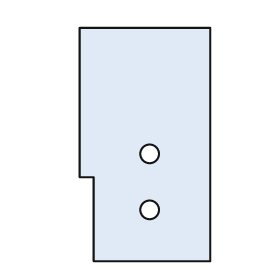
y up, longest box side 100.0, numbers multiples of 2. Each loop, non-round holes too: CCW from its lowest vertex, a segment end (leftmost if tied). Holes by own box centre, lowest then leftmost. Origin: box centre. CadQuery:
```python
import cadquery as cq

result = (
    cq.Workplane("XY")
    .moveTo(-22.0, -50.0)
    .lineTo(28.0, -50.0)
    .lineTo(28.0, 50.0)
    .lineTo(-28.0, 50.0)
    .lineTo(-28.0, -14.0)
    .lineTo(-22.0, -14.0)
    .close()
    .moveTo(2.0, -28.0)
    .circle(4.0)
    .moveTo(2.0, -4.0)
    .circle(4.0)
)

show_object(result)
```